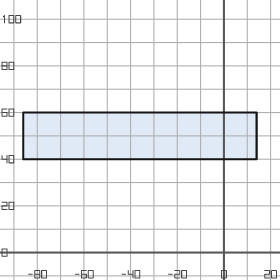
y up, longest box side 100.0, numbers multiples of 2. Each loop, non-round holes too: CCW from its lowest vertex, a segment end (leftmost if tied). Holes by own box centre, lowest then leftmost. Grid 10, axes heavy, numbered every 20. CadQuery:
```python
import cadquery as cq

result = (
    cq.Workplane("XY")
    .moveTo(-86.0, 40.0)
    .lineTo(14.0, 40.0)
    .lineTo(14.0, 60.0)
    .lineTo(-86.0, 60.0)
    .close()
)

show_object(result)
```